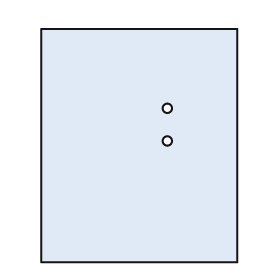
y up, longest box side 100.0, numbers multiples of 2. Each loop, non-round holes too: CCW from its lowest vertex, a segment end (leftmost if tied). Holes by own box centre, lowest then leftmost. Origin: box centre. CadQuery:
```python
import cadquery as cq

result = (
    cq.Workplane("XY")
    .moveTo(-42.0, -50.0)
    .lineTo(42.0, -50.0)
    .lineTo(42.0, 50.0)
    .lineTo(-42.0, 50.0)
    .close()
    .moveTo(12.0, 2.0)
    .circle(2.0)
    .moveTo(12.0, 16.0)
    .circle(2.0)
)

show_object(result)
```